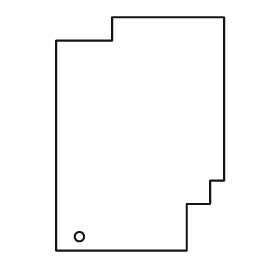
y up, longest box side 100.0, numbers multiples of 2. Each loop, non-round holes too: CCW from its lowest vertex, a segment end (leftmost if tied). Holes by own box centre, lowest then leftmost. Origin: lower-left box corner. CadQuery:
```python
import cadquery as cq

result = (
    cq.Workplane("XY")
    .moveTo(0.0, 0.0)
    .lineTo(56.0, 0.0)
    .lineTo(56.0, 20.0)
    .lineTo(66.0, 20.0)
    .lineTo(66.0, 30.0)
    .lineTo(72.0, 30.0)
    .lineTo(72.0, 100.0)
    .lineTo(24.0, 100.0)
    .lineTo(24.0, 90.0)
    .lineTo(0.0, 90.0)
    .close()
    .moveTo(10.0, 6.0)
    .circle(2.0)
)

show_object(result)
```